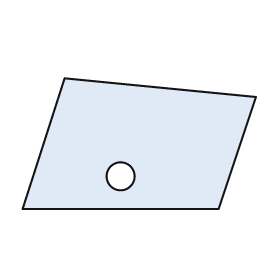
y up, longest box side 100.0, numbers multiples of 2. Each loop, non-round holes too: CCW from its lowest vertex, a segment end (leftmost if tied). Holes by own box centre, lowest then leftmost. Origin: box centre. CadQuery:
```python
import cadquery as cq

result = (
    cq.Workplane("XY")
    .moveTo(-50.0, -28.0)
    .lineTo(34.0, -28.0)
    .lineTo(50.0, 20.0)
    .lineTo(-32.0, 28.0)
    .close()
    .moveTo(-8.0, -14.0)
    .circle(6.0)
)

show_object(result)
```